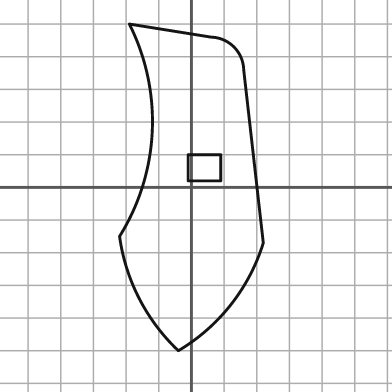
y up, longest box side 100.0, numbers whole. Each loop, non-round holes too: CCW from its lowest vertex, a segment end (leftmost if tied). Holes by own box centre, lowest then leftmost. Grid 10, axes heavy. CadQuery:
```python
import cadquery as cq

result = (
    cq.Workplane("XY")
    .moveTo(-4.0, -50.0)
    .threePointArc((12.0, -36.0), (22.0, -17.0))
    .lineTo(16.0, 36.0)
    .threePointArc((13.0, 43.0), (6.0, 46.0))
    .lineTo(-19.0, 50.0)
    .threePointArc((-12.0, 17.0), (-22.0, -15.0))
    .threePointArc((-16.0, -34.0), (-4.0, -50.0))
    .close()
    .moveTo(-1.0, 2.0)
    .lineTo(9.0, 2.0)
    .lineTo(9.0, 10.0)
    .lineTo(-1.0, 10.0)
    .close()
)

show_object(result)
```